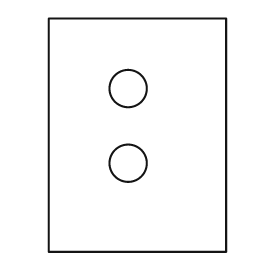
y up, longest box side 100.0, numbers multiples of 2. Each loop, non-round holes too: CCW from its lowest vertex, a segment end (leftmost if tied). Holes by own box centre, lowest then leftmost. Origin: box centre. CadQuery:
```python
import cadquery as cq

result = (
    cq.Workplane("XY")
    .moveTo(-38.0, -50.0)
    .lineTo(38.0, -50.0)
    .lineTo(38.0, 50.0)
    .lineTo(-38.0, 50.0)
    .close()
    .moveTo(-4.0, -12.0)
    .circle(8.0)
    .moveTo(-4.0, 20.0)
    .circle(8.0)
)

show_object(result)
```